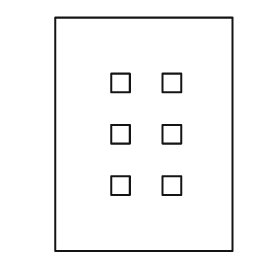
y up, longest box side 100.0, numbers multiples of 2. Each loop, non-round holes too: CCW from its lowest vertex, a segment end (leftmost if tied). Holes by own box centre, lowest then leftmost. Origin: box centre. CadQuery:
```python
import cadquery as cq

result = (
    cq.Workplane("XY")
    .moveTo(-38.0, -50.0)
    .lineTo(38.0, -50.0)
    .lineTo(38.0, 50.0)
    .lineTo(-38.0, 50.0)
    .close()
    .moveTo(-14.0, -26.0)
    .lineTo(-6.0, -26.0)
    .lineTo(-6.0, -18.0)
    .lineTo(-14.0, -18.0)
    .close()
    .moveTo(8.0, -26.0)
    .lineTo(16.0, -26.0)
    .lineTo(16.0, -18.0)
    .lineTo(8.0, -18.0)
    .close()
    .moveTo(-14.0, -4.0)
    .lineTo(-6.0, -4.0)
    .lineTo(-6.0, 4.0)
    .lineTo(-14.0, 4.0)
    .close()
    .moveTo(8.0, -4.0)
    .lineTo(16.0, -4.0)
    .lineTo(16.0, 4.0)
    .lineTo(8.0, 4.0)
    .close()
    .moveTo(-14.0, 18.0)
    .lineTo(-6.0, 18.0)
    .lineTo(-6.0, 26.0)
    .lineTo(-14.0, 26.0)
    .close()
    .moveTo(8.0, 18.0)
    .lineTo(16.0, 18.0)
    .lineTo(16.0, 26.0)
    .lineTo(8.0, 26.0)
    .close()
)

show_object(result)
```